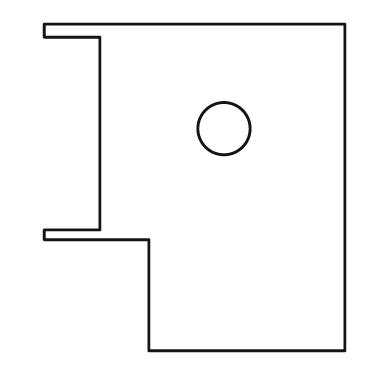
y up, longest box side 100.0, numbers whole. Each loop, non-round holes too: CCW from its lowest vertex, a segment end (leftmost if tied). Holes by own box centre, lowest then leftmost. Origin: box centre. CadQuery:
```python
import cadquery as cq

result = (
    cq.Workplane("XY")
    .moveTo(-14.0, -50.0)
    .lineTo(46.0, -50.0)
    .lineTo(46.0, 50.0)
    .lineTo(-46.0, 50.0)
    .lineTo(-46.0, 46.0)
    .lineTo(-29.0, 46.0)
    .lineTo(-29.0, -13.0)
    .lineTo(-46.0, -13.0)
    .lineTo(-46.0, -16.0)
    .lineTo(-14.0, -16.0)
    .close()
    .moveTo(9.0, 18.0)
    .circle(8.0)
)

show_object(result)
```